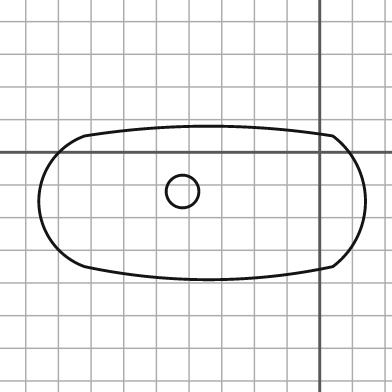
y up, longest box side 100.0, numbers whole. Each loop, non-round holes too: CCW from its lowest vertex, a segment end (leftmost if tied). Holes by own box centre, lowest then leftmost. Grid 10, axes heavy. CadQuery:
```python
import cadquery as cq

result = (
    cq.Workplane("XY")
    .moveTo(-72.0, -35.0)
    .threePointArc((-34.0, -39.0), (4.0, -35.0))
    .threePointArc((14.0, -15.0), (4.0, 5.0))
    .threePointArc((-34.0, 8.0), (-72.0, 5.0))
    .threePointArc((-86.0, -15.0), (-72.0, -35.0))
    .close()
    .moveTo(-42.0, -12.0)
    .circle(5.0)
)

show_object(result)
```